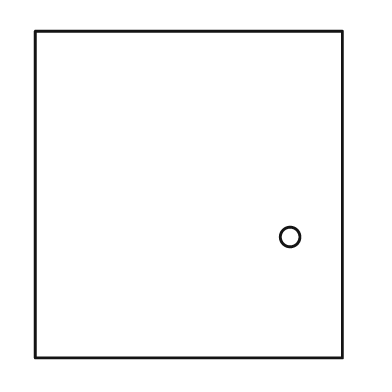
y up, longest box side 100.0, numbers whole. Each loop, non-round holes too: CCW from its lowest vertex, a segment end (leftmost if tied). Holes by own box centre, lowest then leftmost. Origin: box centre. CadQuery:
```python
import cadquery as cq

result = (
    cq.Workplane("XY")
    .moveTo(-47.0, -50.0)
    .lineTo(47.0, -50.0)
    .lineTo(47.0, 50.0)
    .lineTo(-47.0, 50.0)
    .close()
    .moveTo(31.0, -13.0)
    .circle(3.0)
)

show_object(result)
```